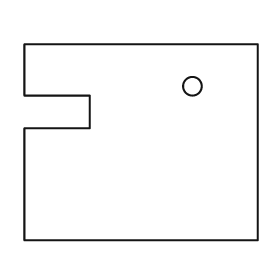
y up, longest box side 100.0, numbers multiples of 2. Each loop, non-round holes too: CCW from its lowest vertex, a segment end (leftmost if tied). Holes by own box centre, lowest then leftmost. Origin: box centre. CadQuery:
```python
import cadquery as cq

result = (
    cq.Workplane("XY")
    .moveTo(-50.0, -42.0)
    .lineTo(50.0, -42.0)
    .lineTo(50.0, 42.0)
    .lineTo(-50.0, 42.0)
    .lineTo(-50.0, 20.0)
    .lineTo(-22.0, 20.0)
    .lineTo(-22.0, 6.0)
    .lineTo(-50.0, 6.0)
    .close()
    .moveTo(22.0, 24.0)
    .circle(4.0)
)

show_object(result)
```